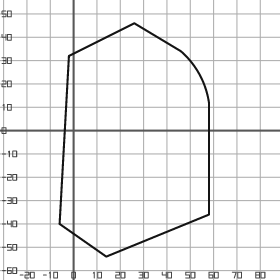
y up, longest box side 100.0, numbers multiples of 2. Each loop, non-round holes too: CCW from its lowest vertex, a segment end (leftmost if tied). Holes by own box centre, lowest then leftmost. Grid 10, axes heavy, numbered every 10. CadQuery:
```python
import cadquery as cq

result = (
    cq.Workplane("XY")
    .moveTo(14.0, -54.0)
    .lineTo(58.0, -36.0)
    .lineTo(58.0, 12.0)
    .threePointArc((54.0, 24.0), (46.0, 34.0))
    .lineTo(26.0, 46.0)
    .lineTo(-2.0, 32.0)
    .lineTo(-6.0, -40.0)
    .close()
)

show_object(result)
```